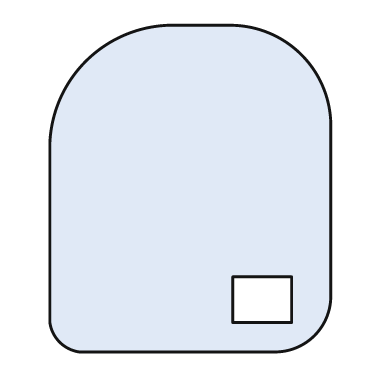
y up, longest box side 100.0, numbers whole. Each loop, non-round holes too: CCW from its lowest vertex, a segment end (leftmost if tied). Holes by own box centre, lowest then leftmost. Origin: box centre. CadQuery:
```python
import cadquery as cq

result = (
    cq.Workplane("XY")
    .moveTo(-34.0, -50.0)
    .lineTo(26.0, -50.0)
    .threePointArc((38.0, -45.0), (43.0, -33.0))
    .lineTo(43.0, 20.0)
    .threePointArc((34.0, 41.0), (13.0, 50.0))
    .lineTo(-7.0, 50.0)
    .threePointArc((-32.0, 39.0), (-43.0, 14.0))
    .lineTo(-43.0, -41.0)
    .threePointArc((-40.0, -47.0), (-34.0, -50.0))
    .close()
    .moveTo(13.0, -41.0)
    .lineTo(31.0, -41.0)
    .lineTo(31.0, -27.0)
    .lineTo(13.0, -27.0)
    .close()
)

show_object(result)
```